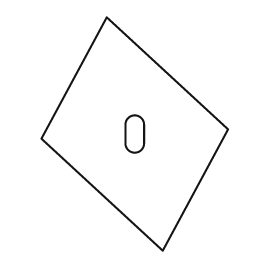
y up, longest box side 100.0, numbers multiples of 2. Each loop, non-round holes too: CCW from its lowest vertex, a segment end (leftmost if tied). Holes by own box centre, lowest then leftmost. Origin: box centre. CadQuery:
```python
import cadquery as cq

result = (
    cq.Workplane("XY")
    .moveTo(12.0, -50.0)
    .lineTo(40.0, 2.0)
    .lineTo(-12.0, 50.0)
    .lineTo(-40.0, -2.0)
    .close()
    .moveTo(-4.0, -4.0)
    .threePointArc((0.0, -8.0), (4.0, -4.0))
    .lineTo(4.0, 4.0)
    .threePointArc((0.0, 8.0), (-4.0, 4.0))
    .close()
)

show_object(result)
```